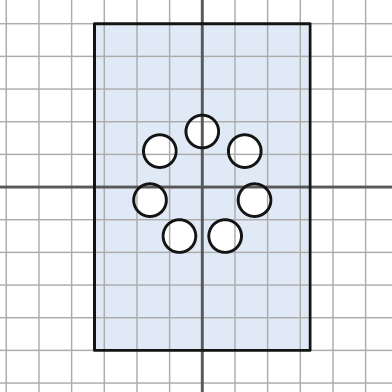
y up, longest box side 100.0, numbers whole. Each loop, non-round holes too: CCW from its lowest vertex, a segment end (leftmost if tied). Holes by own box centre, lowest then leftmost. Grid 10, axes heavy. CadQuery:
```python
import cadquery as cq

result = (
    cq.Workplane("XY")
    .moveTo(-33.0, -50.0)
    .lineTo(33.0, -50.0)
    .lineTo(33.0, 50.0)
    .lineTo(-33.0, 50.0)
    .close()
    .moveTo(-7.0, -15.0)
    .circle(5.0)
    .moveTo(7.0, -15.0)
    .circle(5.0)
    .moveTo(-16.0, -4.0)
    .circle(5.0)
    .moveTo(16.0, -4.0)
    .circle(5.0)
    .moveTo(-13.0, 11.0)
    .circle(5.0)
    .moveTo(13.0, 11.0)
    .circle(5.0)
    .moveTo(0.0, 17.0)
    .circle(5.0)
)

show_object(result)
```